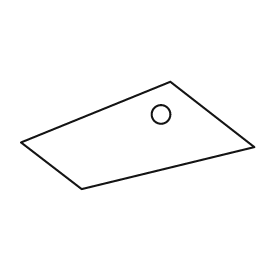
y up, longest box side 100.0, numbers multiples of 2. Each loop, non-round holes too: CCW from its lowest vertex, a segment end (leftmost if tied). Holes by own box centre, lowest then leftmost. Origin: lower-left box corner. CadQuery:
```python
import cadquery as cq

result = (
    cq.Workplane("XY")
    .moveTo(26.0, 0.0)
    .lineTo(100.0, 18.0)
    .lineTo(64.0, 46.0)
    .lineTo(0.0, 20.0)
    .close()
    .moveTo(60.0, 32.0)
    .circle(4.0)
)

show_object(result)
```